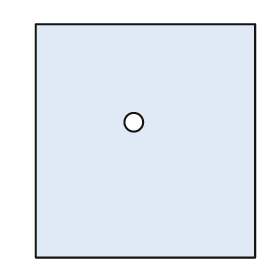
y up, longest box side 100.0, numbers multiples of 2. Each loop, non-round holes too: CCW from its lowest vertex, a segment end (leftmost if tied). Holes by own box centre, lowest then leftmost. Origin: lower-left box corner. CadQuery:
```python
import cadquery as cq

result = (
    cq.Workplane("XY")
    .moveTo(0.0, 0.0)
    .lineTo(94.0, 0.0)
    .lineTo(94.0, 100.0)
    .lineTo(0.0, 100.0)
    .close()
    .moveTo(42.0, 58.0)
    .circle(4.0)
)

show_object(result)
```